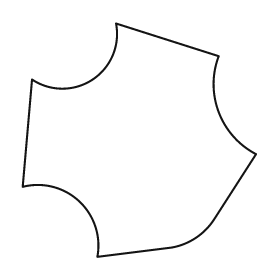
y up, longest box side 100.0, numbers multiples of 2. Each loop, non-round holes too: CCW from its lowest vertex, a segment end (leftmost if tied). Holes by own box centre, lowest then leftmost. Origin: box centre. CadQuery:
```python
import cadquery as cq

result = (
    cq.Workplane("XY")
    .moveTo(-18.0, -50.0)
    .lineTo(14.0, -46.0)
    .threePointArc((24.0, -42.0), (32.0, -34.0))
    .lineTo(50.0, -6.0)
    .threePointArc((34.0, 12.0), (34.0, 36.0))
    .lineTo(-10.0, 50.0)
    .threePointArc((-20.0, 26.0), (-46.0, 26.0))
    .lineTo(-50.0, -20.0)
    .threePointArc((-26.0, -26.0), (-18.0, -50.0))
    .close()
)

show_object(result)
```